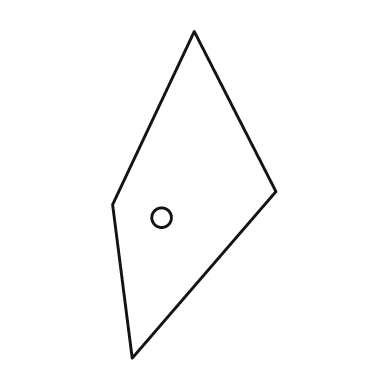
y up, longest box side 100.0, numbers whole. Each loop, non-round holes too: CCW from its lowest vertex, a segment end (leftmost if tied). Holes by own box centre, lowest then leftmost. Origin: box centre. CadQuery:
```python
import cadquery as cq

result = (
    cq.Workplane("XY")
    .moveTo(-19.0, -50.0)
    .lineTo(25.0, 1.0)
    .lineTo(0.0, 50.0)
    .lineTo(-25.0, -3.0)
    .close()
    .moveTo(-10.0, -7.0)
    .circle(3.0)
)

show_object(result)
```